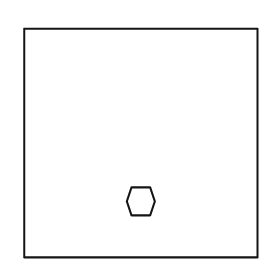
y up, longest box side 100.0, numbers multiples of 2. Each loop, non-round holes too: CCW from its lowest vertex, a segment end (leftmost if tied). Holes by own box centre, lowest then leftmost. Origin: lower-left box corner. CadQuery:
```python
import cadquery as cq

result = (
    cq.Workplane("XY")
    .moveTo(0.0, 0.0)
    .lineTo(100.0, 0.0)
    .lineTo(100.0, 98.0)
    .lineTo(0.0, 98.0)
    .close()
    .moveTo(46.0, 18.0)
    .lineTo(54.0, 18.0)
    .lineTo(56.0, 24.0)
    .lineTo(54.0, 30.0)
    .lineTo(46.0, 30.0)
    .lineTo(44.0, 24.0)
    .close()
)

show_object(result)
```